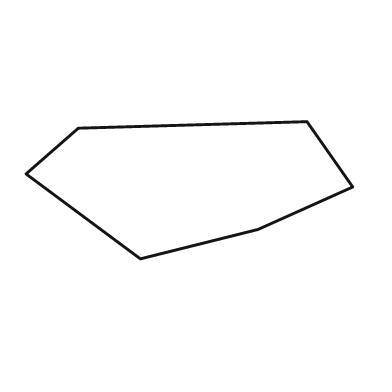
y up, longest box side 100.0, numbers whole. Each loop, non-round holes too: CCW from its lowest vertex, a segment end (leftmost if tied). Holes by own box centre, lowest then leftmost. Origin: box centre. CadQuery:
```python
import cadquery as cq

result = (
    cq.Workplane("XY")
    .moveTo(-15.0, -21.0)
    .lineTo(21.0, -12.0)
    .lineTo(50.0, 1.0)
    .lineTo(36.0, 21.0)
    .lineTo(-34.0, 19.0)
    .lineTo(-50.0, 5.0)
    .close()
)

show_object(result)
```